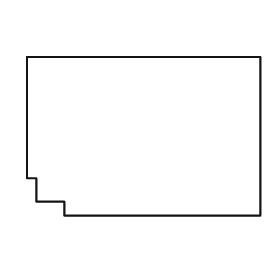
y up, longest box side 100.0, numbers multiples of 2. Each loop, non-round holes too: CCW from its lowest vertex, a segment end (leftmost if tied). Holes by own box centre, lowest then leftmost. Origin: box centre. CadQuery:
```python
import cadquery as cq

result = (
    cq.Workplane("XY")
    .moveTo(-34.0, -34.0)
    .lineTo(50.0, -34.0)
    .lineTo(50.0, 34.0)
    .lineTo(-50.0, 34.0)
    .lineTo(-50.0, -18.0)
    .lineTo(-46.0, -18.0)
    .lineTo(-46.0, -28.0)
    .lineTo(-34.0, -28.0)
    .close()
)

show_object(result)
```